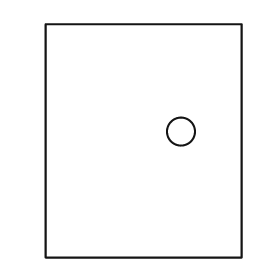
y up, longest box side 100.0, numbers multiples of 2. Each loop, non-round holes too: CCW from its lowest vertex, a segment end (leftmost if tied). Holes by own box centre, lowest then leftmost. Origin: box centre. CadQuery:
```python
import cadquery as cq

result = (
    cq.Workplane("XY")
    .moveTo(-42.0, -50.0)
    .lineTo(42.0, -50.0)
    .lineTo(42.0, 50.0)
    .lineTo(-42.0, 50.0)
    .close()
    .moveTo(16.0, 4.0)
    .circle(6.0)
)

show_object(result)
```